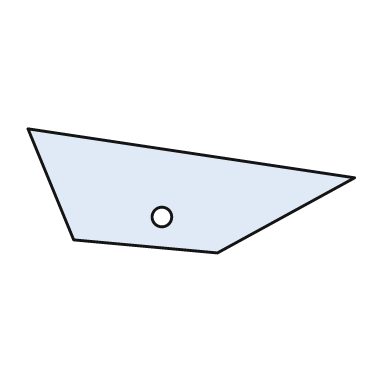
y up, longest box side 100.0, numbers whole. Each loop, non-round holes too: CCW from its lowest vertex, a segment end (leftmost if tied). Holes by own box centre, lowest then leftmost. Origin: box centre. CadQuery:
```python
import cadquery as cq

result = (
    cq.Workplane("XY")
    .moveTo(8.0, -19.0)
    .lineTo(50.0, 4.0)
    .lineTo(-50.0, 19.0)
    .lineTo(-36.0, -15.0)
    .close()
    .moveTo(-9.0, -8.0)
    .circle(3.0)
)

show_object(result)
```